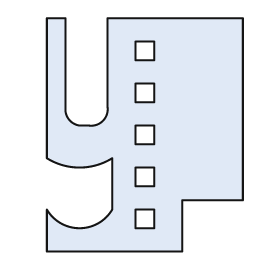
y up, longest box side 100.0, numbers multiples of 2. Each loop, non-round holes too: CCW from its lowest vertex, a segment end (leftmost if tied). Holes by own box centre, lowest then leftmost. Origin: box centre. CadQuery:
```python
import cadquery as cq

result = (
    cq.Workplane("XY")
    .moveTo(-42.0, -50.0)
    .lineTo(16.0, -50.0)
    .lineTo(16.0, -28.0)
    .lineTo(42.0, -28.0)
    .lineTo(42.0, 50.0)
    .lineTo(-16.0, 50.0)
    .lineTo(-16.0, 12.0)
    .threePointArc((-18.0, 6.0), (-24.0, 4.0))
    .lineTo(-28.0, 4.0)
    .threePointArc((-32.0, 6.0), (-34.0, 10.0))
    .lineTo(-34.0, 50.0)
    .lineTo(-42.0, 50.0)
    .lineTo(-42.0, -10.0)
    .threePointArc((-28.0, -14.0), (-14.0, -10.0))
    .lineTo(-14.0, -32.0)
    .threePointArc((-28.0, -40.0), (-42.0, -32.0))
    .close()
    .moveTo(-4.0, -40.0)
    .lineTo(4.0, -40.0)
    .lineTo(4.0, -32.0)
    .lineTo(-4.0, -32.0)
    .close()
    .moveTo(-4.0, -22.0)
    .lineTo(4.0, -22.0)
    .lineTo(4.0, -14.0)
    .lineTo(-4.0, -14.0)
    .close()
    .moveTo(-4.0, -4.0)
    .lineTo(4.0, -4.0)
    .lineTo(4.0, 4.0)
    .lineTo(-4.0, 4.0)
    .close()
    .moveTo(-4.0, 14.0)
    .lineTo(4.0, 14.0)
    .lineTo(4.0, 22.0)
    .lineTo(-4.0, 22.0)
    .close()
    .moveTo(-4.0, 32.0)
    .lineTo(4.0, 32.0)
    .lineTo(4.0, 40.0)
    .lineTo(-4.0, 40.0)
    .close()
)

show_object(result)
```